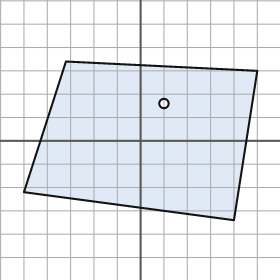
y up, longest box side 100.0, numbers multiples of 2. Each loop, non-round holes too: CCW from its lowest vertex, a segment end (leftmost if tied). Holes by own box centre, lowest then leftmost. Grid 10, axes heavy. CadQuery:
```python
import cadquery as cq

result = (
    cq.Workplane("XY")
    .moveTo(40.0, -34.0)
    .lineTo(50.0, 30.0)
    .lineTo(-32.0, 34.0)
    .lineTo(-50.0, -22.0)
    .close()
    .moveTo(10.0, 16.0)
    .circle(2.0)
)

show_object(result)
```